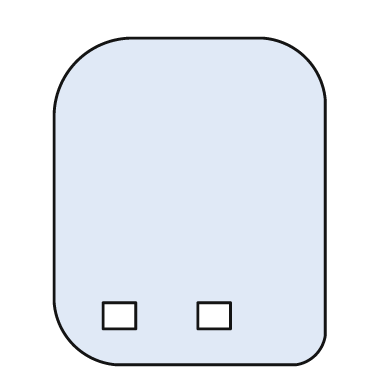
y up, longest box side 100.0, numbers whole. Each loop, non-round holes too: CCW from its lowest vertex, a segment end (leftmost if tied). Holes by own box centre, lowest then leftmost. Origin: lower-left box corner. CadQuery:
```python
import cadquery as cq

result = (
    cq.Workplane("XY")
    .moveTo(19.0, 0.0)
    .lineTo(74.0, 0.0)
    .threePointArc((80.0, 3.0), (83.0, 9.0))
    .lineTo(83.0, 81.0)
    .threePointArc((77.0, 94.0), (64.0, 100.0))
    .lineTo(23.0, 100.0)
    .threePointArc((7.0, 93.0), (0.0, 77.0))
    .lineTo(0.0, 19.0)
    .threePointArc((6.0, 6.0), (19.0, 0.0))
    .close()
    .moveTo(15.0, 11.0)
    .lineTo(25.0, 11.0)
    .lineTo(25.0, 19.0)
    .lineTo(15.0, 19.0)
    .close()
    .moveTo(44.0, 11.0)
    .lineTo(54.0, 11.0)
    .lineTo(54.0, 19.0)
    .lineTo(44.0, 19.0)
    .close()
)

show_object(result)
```